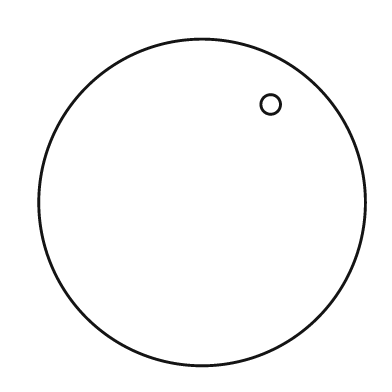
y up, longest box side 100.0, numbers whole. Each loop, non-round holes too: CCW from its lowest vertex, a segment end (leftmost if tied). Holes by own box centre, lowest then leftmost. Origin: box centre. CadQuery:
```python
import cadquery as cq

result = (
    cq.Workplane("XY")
    .moveTo(0.0, 0.0)
    .circle(50.0)
    .moveTo(21.0, 30.0)
    .circle(3.0)
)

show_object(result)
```